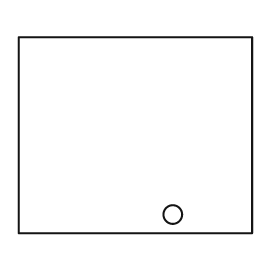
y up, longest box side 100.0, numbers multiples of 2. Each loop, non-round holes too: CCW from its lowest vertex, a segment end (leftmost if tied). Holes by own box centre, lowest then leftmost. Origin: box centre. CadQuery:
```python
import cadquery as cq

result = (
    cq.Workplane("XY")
    .moveTo(-50.0, -42.0)
    .lineTo(50.0, -42.0)
    .lineTo(50.0, 42.0)
    .lineTo(-50.0, 42.0)
    .close()
    .moveTo(16.0, -34.0)
    .circle(4.0)
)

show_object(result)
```